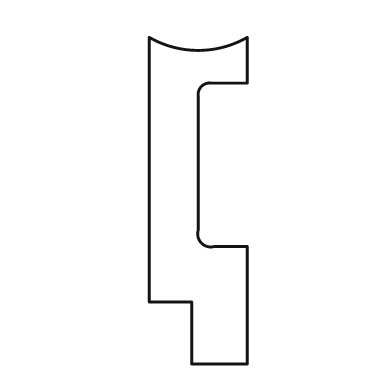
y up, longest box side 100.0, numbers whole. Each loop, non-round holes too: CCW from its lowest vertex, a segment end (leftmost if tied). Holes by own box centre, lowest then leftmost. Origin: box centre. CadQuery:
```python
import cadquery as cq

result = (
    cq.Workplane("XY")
    .moveTo(-2.0, -50.0)
    .lineTo(15.0, -50.0)
    .lineTo(15.0, -14.0)
    .lineTo(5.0, -14.0)
    .threePointArc((1.0, -13.0), (0.0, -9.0))
    .lineTo(0.0, 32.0)
    .threePointArc((1.0, 35.0), (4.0, 36.0))
    .lineTo(15.0, 36.0)
    .lineTo(15.0, 50.0)
    .threePointArc((0.0, 46.0), (-15.0, 50.0))
    .lineTo(-15.0, -31.0)
    .lineTo(-2.0, -31.0)
    .close()
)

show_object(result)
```